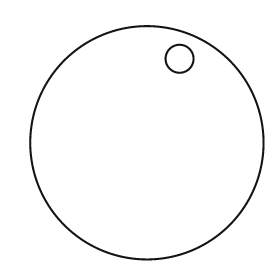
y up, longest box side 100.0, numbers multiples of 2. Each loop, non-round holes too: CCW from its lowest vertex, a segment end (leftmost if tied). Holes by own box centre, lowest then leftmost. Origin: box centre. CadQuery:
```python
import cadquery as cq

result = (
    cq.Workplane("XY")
    .moveTo(0.0, 0.0)
    .circle(50.0)
    .moveTo(14.0, 36.0)
    .circle(6.0)
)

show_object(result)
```